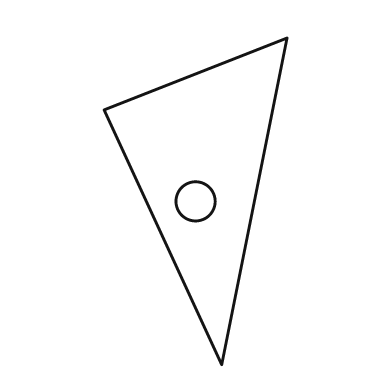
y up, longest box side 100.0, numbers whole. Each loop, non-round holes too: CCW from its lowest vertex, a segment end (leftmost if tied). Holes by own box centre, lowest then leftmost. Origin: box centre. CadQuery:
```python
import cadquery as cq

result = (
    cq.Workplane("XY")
    .moveTo(8.0, -50.0)
    .lineTo(28.0, 50.0)
    .lineTo(-28.0, 28.0)
    .close()
    .moveTo(0.0, 0.0)
    .circle(6.0)
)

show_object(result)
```